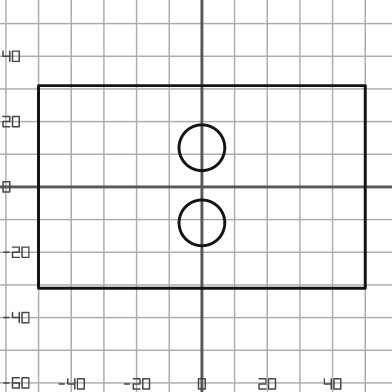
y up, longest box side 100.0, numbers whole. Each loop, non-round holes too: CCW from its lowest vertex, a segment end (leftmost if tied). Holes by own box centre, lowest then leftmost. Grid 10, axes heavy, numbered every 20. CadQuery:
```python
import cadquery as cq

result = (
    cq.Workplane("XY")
    .moveTo(-50.0, -31.0)
    .lineTo(50.0, -31.0)
    .lineTo(50.0, 31.0)
    .lineTo(-50.0, 31.0)
    .close()
    .moveTo(0.0, -11.0)
    .circle(7.0)
    .moveTo(0.0, 12.0)
    .circle(7.0)
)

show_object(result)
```